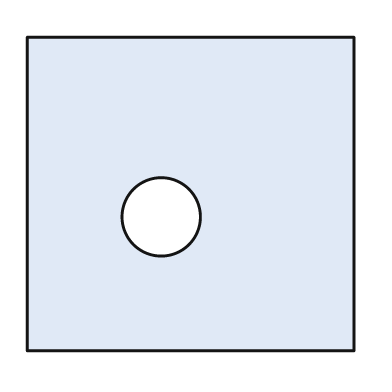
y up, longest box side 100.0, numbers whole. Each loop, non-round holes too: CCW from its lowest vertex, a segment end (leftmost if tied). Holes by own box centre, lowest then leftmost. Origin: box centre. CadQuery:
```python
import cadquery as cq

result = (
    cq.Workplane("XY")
    .moveTo(-50.0, -48.0)
    .lineTo(50.0, -48.0)
    .lineTo(50.0, 48.0)
    .lineTo(-50.0, 48.0)
    .close()
    .moveTo(-9.0, -7.0)
    .circle(12.0)
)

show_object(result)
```